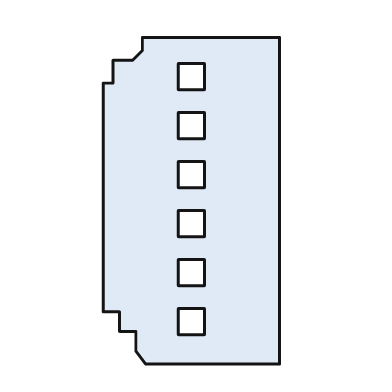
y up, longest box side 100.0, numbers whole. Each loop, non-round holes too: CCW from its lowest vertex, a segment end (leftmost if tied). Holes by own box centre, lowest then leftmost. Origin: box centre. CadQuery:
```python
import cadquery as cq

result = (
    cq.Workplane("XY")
    .moveTo(-14.0, -50.0)
    .lineTo(27.0, -50.0)
    .lineTo(27.0, 50.0)
    .lineTo(-15.0, 50.0)
    .lineTo(-15.0, 46.0)
    .lineTo(-18.0, 43.0)
    .lineTo(-24.0, 43.0)
    .lineTo(-24.0, 36.0)
    .lineTo(-27.0, 36.0)
    .lineTo(-27.0, -34.0)
    .lineTo(-22.0, -34.0)
    .lineTo(-22.0, -40.0)
    .lineTo(-17.0, -40.0)
    .lineTo(-17.0, -46.0)
    .close()
    .moveTo(-4.0, -41.0)
    .lineTo(4.0, -41.0)
    .lineTo(4.0, -33.0)
    .lineTo(-4.0, -33.0)
    .close()
    .moveTo(-4.0, -26.0)
    .lineTo(4.0, -26.0)
    .lineTo(4.0, -18.0)
    .lineTo(-4.0, -18.0)
    .close()
    .moveTo(-4.0, -11.0)
    .lineTo(4.0, -11.0)
    .lineTo(4.0, -3.0)
    .lineTo(-4.0, -3.0)
    .close()
    .moveTo(-4.0, 4.0)
    .lineTo(4.0, 4.0)
    .lineTo(4.0, 12.0)
    .lineTo(-4.0, 12.0)
    .close()
    .moveTo(-4.0, 19.0)
    .lineTo(4.0, 19.0)
    .lineTo(4.0, 27.0)
    .lineTo(-4.0, 27.0)
    .close()
    .moveTo(-4.0, 34.0)
    .lineTo(4.0, 34.0)
    .lineTo(4.0, 42.0)
    .lineTo(-4.0, 42.0)
    .close()
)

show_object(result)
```